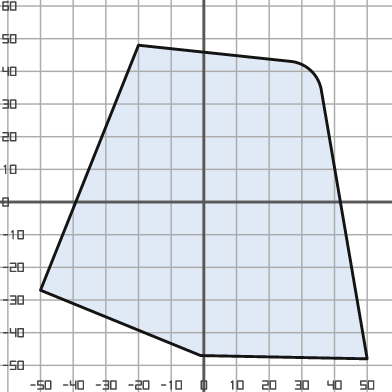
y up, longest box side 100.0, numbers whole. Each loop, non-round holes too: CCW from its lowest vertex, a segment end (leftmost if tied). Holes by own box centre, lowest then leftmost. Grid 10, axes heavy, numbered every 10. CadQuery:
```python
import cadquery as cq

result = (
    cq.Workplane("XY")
    .moveTo(50.0, -48.0)
    .lineTo(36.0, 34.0)
    .threePointArc((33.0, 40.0), (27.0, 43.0))
    .lineTo(-20.0, 48.0)
    .lineTo(-50.0, -27.0)
    .lineTo(-1.0, -47.0)
    .close()
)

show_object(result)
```